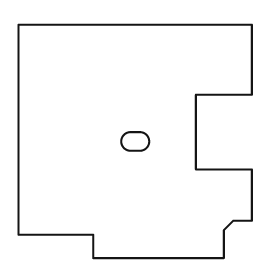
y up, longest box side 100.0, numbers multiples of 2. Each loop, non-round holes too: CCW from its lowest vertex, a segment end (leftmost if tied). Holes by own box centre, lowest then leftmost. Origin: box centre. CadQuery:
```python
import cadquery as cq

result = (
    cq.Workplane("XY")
    .moveTo(-18.0, -50.0)
    .lineTo(38.0, -50.0)
    .lineTo(38.0, -38.0)
    .lineTo(42.0, -34.0)
    .lineTo(50.0, -34.0)
    .lineTo(50.0, -12.0)
    .lineTo(26.0, -12.0)
    .lineTo(26.0, 20.0)
    .lineTo(50.0, 20.0)
    .lineTo(50.0, 50.0)
    .lineTo(-50.0, 50.0)
    .lineTo(-50.0, -40.0)
    .lineTo(-18.0, -40.0)
    .close()
    .moveTo(-2.0, -4.0)
    .lineTo(2.0, -4.0)
    .threePointArc((6.0, 0.0), (2.0, 4.0))
    .lineTo(-2.0, 4.0)
    .threePointArc((-6.0, 0.0), (-2.0, -4.0))
    .close()
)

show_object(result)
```